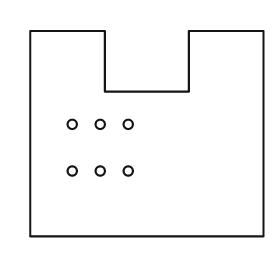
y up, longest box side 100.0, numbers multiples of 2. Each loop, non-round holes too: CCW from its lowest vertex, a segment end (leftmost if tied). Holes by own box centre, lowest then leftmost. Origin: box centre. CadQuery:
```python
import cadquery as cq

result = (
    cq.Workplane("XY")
    .moveTo(-50.0, -44.0)
    .lineTo(50.0, -44.0)
    .lineTo(50.0, 44.0)
    .lineTo(18.0, 44.0)
    .lineTo(18.0, 18.0)
    .lineTo(-18.0, 18.0)
    .lineTo(-18.0, 44.0)
    .lineTo(-50.0, 44.0)
    .close()
    .moveTo(-32.0, -16.0)
    .circle(2.0)
    .moveTo(-20.0, -16.0)
    .circle(2.0)
    .moveTo(-8.0, -16.0)
    .circle(2.0)
    .moveTo(-32.0, 4.0)
    .circle(2.0)
    .moveTo(-20.0, 4.0)
    .circle(2.0)
    .moveTo(-8.0, 4.0)
    .circle(2.0)
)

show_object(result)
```